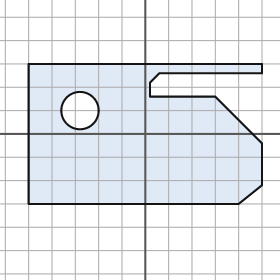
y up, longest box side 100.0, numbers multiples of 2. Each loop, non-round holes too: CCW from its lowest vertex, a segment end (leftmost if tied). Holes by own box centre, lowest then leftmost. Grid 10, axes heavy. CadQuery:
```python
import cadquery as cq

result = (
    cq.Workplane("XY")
    .moveTo(-50.0, -30.0)
    .lineTo(40.0, -30.0)
    .lineTo(50.0, -22.0)
    .lineTo(50.0, -4.0)
    .lineTo(30.0, 16.0)
    .lineTo(2.0, 16.0)
    .lineTo(2.0, 22.0)
    .lineTo(6.0, 26.0)
    .lineTo(50.0, 26.0)
    .lineTo(50.0, 30.0)
    .lineTo(-50.0, 30.0)
    .close()
    .moveTo(-28.0, 10.0)
    .circle(8.0)
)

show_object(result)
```